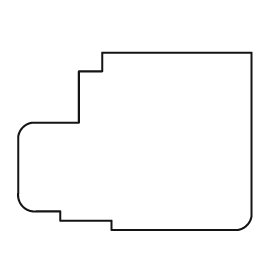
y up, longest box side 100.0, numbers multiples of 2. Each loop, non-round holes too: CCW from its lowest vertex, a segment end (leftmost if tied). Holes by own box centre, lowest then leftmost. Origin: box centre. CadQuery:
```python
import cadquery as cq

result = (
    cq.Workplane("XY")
    .moveTo(-10.0, -38.0)
    .lineTo(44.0, -38.0)
    .threePointArc((48.0, -36.0), (50.0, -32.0))
    .lineTo(50.0, 38.0)
    .lineTo(-14.0, 38.0)
    .lineTo(-14.0, 30.0)
    .lineTo(-24.0, 30.0)
    .lineTo(-24.0, 8.0)
    .lineTo(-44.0, 8.0)
    .threePointArc((-48.0, 6.0), (-50.0, 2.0))
    .lineTo(-50.0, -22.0)
    .threePointArc((-48.0, -28.0), (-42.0, -30.0))
    .lineTo(-32.0, -30.0)
    .lineTo(-32.0, -34.0)
    .lineTo(-10.0, -34.0)
    .close()
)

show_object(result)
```